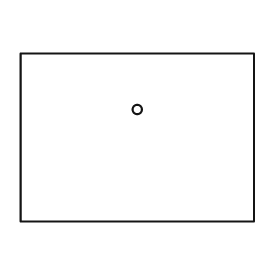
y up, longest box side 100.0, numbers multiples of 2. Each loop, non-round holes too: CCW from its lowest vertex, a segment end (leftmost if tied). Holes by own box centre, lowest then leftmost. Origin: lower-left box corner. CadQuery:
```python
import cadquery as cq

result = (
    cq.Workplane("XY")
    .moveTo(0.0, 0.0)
    .lineTo(100.0, 0.0)
    .lineTo(100.0, 72.0)
    .lineTo(0.0, 72.0)
    .close()
    .moveTo(50.0, 48.0)
    .circle(2.0)
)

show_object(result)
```